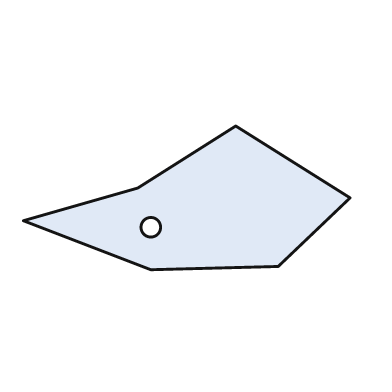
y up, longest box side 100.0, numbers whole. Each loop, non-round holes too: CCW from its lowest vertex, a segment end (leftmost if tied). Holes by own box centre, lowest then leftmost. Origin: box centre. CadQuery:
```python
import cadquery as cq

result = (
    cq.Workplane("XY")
    .moveTo(-11.0, -22.0)
    .lineTo(28.0, -21.0)
    .lineTo(50.0, 0.0)
    .lineTo(15.0, 22.0)
    .lineTo(-15.0, 3.0)
    .lineTo(-50.0, -7.0)
    .close()
    .moveTo(-11.0, -9.0)
    .circle(3.0)
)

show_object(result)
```